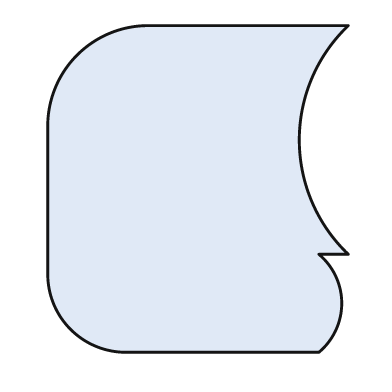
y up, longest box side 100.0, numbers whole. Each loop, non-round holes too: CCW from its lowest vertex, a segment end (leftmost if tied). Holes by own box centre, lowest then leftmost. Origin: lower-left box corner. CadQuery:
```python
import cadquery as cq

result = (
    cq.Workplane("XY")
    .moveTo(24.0, 0.0)
    .lineTo(83.0, 0.0)
    .threePointArc((90.0, 15.0), (83.0, 30.0))
    .lineTo(92.0, 30.0)
    .threePointArc((77.0, 65.0), (92.0, 100.0))
    .lineTo(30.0, 100.0)
    .threePointArc((9.0, 91.0), (0.0, 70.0))
    .lineTo(0.0, 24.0)
    .threePointArc((7.0, 7.0), (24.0, 0.0))
    .close()
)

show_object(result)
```